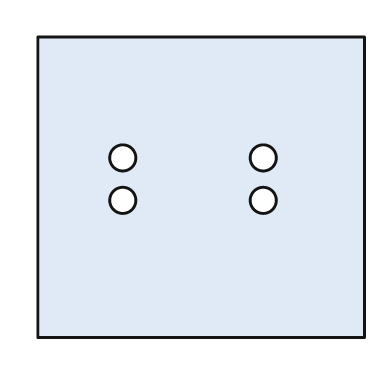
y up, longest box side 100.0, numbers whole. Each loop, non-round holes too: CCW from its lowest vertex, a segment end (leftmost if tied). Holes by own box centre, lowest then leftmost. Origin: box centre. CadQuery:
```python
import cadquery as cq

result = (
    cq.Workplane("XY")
    .moveTo(-50.0, -46.0)
    .lineTo(50.0, -46.0)
    .lineTo(50.0, 46.0)
    .lineTo(-50.0, 46.0)
    .close()
    .moveTo(-24.0, -4.0)
    .circle(4.0)
    .moveTo(19.0, -4.0)
    .circle(4.0)
    .moveTo(-24.0, 9.0)
    .circle(4.0)
    .moveTo(19.0, 9.0)
    .circle(4.0)
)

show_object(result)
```